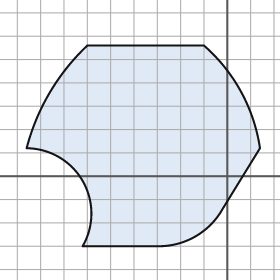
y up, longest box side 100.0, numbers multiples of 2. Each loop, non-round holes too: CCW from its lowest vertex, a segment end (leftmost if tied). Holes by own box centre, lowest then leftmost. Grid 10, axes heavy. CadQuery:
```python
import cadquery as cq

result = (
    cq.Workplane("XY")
    .moveTo(-62.0, -30.0)
    .lineTo(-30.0, -30.0)
    .threePointArc((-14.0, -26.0), (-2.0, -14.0))
    .lineTo(14.0, 12.0)
    .threePointArc((6.0, 36.0), (-10.0, 56.0))
    .lineTo(-60.0, 56.0)
    .threePointArc((-76.0, 36.0), (-86.0, 12.0))
    .threePointArc((-62.0, -2.0), (-62.0, -30.0))
    .close()
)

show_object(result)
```